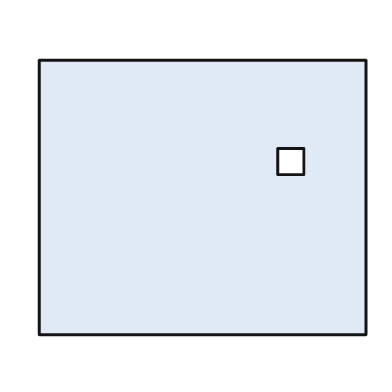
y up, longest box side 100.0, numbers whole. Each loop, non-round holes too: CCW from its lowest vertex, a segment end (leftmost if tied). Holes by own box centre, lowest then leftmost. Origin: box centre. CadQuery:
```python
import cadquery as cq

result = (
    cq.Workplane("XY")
    .moveTo(-50.0, -42.0)
    .lineTo(50.0, -42.0)
    .lineTo(50.0, 42.0)
    .lineTo(-50.0, 42.0)
    .close()
    .moveTo(23.0, 7.0)
    .lineTo(31.0, 7.0)
    .lineTo(31.0, 15.0)
    .lineTo(23.0, 15.0)
    .close()
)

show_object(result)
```